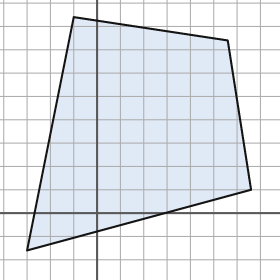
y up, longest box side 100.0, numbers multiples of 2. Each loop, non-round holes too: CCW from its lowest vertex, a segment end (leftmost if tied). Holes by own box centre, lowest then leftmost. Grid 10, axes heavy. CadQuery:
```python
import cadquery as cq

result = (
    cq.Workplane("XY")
    .moveTo(-30.0, -16.0)
    .lineTo(66.0, 10.0)
    .lineTo(56.0, 74.0)
    .lineTo(-10.0, 84.0)
    .close()
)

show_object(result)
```